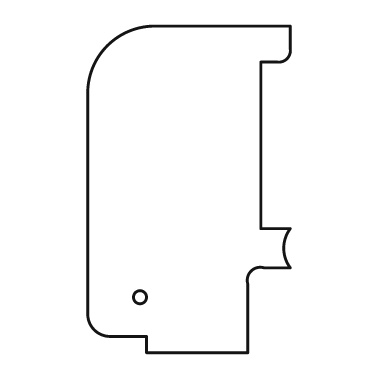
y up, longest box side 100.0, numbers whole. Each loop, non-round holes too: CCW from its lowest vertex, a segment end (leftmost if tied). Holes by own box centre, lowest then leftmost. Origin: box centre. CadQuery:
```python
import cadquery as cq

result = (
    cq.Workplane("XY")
    .moveTo(-13.0, -50.0)
    .lineTo(18.0, -50.0)
    .lineTo(18.0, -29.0)
    .threePointArc((19.0, -25.0), (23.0, -24.0))
    .lineTo(31.0, -24.0)
    .threePointArc((29.0, -18.0), (31.0, -12.0))
    .lineTo(22.0, -12.0)
    .lineTo(22.0, 39.0)
    .lineTo(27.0, 39.0)
    .threePointArc((30.0, 40.0), (31.0, 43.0))
    .lineTo(31.0, 50.0)
    .lineTo(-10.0, 50.0)
    .threePointArc((-25.0, 44.0), (-31.0, 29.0))
    .lineTo(-31.0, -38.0)
    .threePointArc((-29.0, -43.0), (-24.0, -45.0))
    .lineTo(-13.0, -45.0)
    .close()
    .moveTo(-15.0, -33.0)
    .circle(2.0)
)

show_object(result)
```